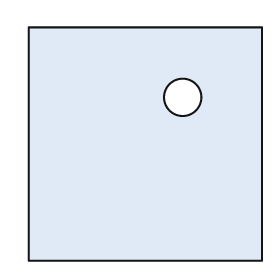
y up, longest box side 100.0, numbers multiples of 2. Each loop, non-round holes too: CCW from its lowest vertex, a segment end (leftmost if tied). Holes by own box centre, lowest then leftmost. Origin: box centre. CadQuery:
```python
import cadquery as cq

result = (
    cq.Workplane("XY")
    .moveTo(-50.0, -50.0)
    .lineTo(50.0, -50.0)
    .lineTo(50.0, 50.0)
    .lineTo(-50.0, 50.0)
    .close()
    .moveTo(16.0, 20.0)
    .circle(8.0)
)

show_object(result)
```